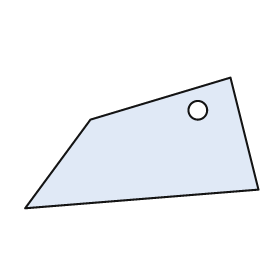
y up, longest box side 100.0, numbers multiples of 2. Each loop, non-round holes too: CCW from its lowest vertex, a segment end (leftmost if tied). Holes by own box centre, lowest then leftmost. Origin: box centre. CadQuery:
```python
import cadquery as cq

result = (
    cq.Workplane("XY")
    .moveTo(-50.0, -28.0)
    .lineTo(50.0, -20.0)
    .lineTo(38.0, 28.0)
    .lineTo(-22.0, 10.0)
    .close()
    .moveTo(24.0, 14.0)
    .circle(4.0)
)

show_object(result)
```